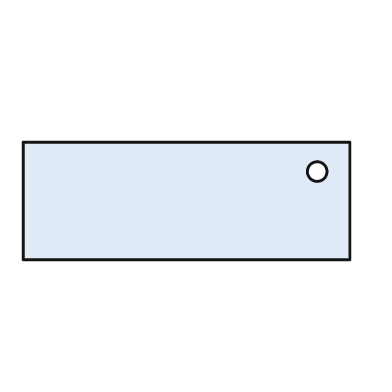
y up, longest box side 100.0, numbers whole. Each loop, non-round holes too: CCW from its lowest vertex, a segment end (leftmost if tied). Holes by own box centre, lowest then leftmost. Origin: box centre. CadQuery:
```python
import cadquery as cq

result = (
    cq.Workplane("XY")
    .moveTo(-50.0, -18.0)
    .lineTo(50.0, -18.0)
    .lineTo(50.0, 18.0)
    .lineTo(-50.0, 18.0)
    .close()
    .moveTo(40.0, 9.0)
    .circle(3.0)
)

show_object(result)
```